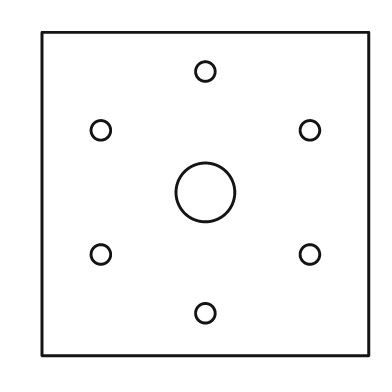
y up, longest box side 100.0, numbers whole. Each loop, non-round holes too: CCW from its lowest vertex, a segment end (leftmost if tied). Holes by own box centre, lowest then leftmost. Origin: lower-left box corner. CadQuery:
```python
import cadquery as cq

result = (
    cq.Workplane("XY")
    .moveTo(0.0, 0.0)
    .lineTo(100.0, 0.0)
    .lineTo(100.0, 99.0)
    .lineTo(0.0, 99.0)
    .close()
    .moveTo(50.0, 13.0)
    .circle(3.0)
    .moveTo(18.0, 31.0)
    .circle(3.0)
    .moveTo(82.0, 31.0)
    .circle(3.0)
    .moveTo(50.0, 50.0)
    .circle(9.0)
    .moveTo(18.0, 69.0)
    .circle(3.0)
    .moveTo(82.0, 69.0)
    .circle(3.0)
    .moveTo(50.0, 87.0)
    .circle(3.0)
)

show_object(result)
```